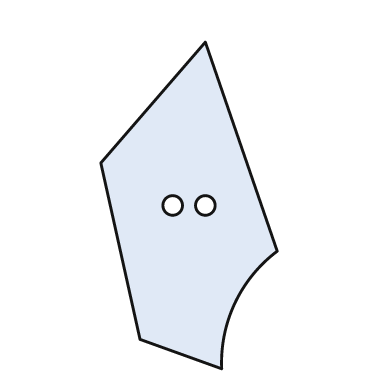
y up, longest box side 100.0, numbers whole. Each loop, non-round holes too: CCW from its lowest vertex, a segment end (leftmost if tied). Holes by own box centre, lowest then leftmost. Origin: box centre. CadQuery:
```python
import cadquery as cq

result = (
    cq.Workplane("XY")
    .moveTo(10.0, -50.0)
    .threePointArc((14.0, -30.0), (27.0, -14.0))
    .lineTo(5.0, 50.0)
    .lineTo(-27.0, 13.0)
    .lineTo(-15.0, -41.0)
    .close()
    .moveTo(-5.0, 0.0)
    .circle(3.0)
    .moveTo(5.0, 0.0)
    .circle(3.0)
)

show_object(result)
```